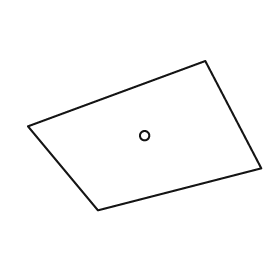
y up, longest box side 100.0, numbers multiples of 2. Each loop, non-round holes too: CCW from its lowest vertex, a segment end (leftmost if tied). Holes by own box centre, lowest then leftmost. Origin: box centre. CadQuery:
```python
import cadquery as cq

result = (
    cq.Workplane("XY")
    .moveTo(-20.0, -32.0)
    .lineTo(50.0, -14.0)
    .lineTo(26.0, 32.0)
    .lineTo(-50.0, 4.0)
    .close()
    .moveTo(0.0, 0.0)
    .circle(2.0)
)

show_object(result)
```